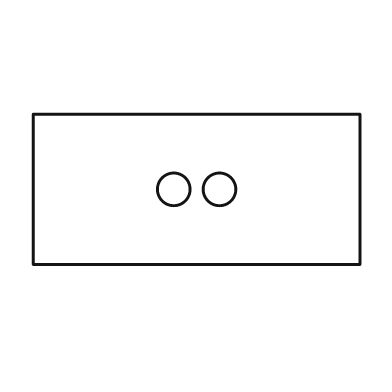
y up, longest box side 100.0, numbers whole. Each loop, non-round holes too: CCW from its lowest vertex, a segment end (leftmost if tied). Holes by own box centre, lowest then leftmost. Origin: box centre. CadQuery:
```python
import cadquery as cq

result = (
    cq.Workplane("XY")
    .moveTo(-50.0, -23.0)
    .lineTo(50.0, -23.0)
    .lineTo(50.0, 23.0)
    .lineTo(-50.0, 23.0)
    .close()
    .moveTo(-7.0, 0.0)
    .circle(5.0)
    .moveTo(7.0, 0.0)
    .circle(5.0)
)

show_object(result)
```